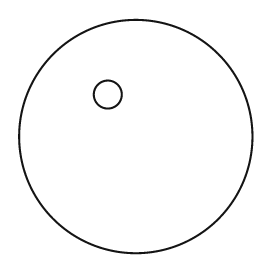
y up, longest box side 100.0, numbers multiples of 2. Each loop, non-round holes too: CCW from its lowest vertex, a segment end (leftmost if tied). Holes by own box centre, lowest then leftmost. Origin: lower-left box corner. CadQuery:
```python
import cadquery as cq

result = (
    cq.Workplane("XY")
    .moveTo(50.0, 50.0)
    .circle(50.0)
    .moveTo(38.0, 68.0)
    .circle(6.0)
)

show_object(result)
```